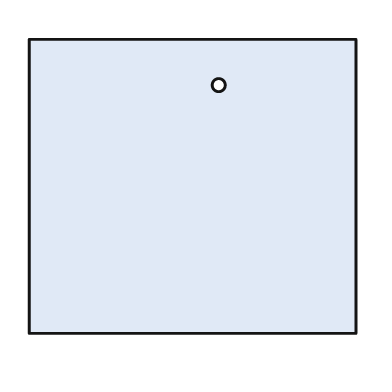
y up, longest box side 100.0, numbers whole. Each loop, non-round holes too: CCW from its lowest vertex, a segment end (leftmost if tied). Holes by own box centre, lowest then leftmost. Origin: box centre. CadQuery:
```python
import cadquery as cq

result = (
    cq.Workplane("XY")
    .moveTo(-50.0, -45.0)
    .lineTo(50.0, -45.0)
    .lineTo(50.0, 45.0)
    .lineTo(-50.0, 45.0)
    .close()
    .moveTo(8.0, 31.0)
    .circle(2.0)
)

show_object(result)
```